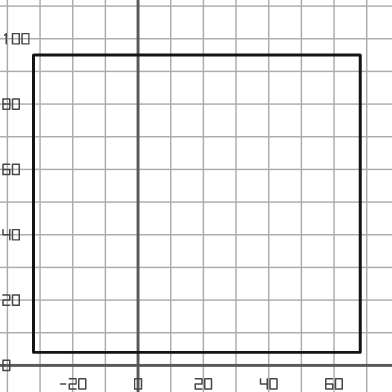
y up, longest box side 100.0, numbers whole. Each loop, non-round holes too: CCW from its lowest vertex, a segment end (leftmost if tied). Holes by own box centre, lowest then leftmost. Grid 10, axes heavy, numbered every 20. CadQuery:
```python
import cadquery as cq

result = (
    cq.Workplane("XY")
    .moveTo(-32.0, 4.0)
    .lineTo(68.0, 4.0)
    .lineTo(68.0, 95.0)
    .lineTo(-32.0, 95.0)
    .close()
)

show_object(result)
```